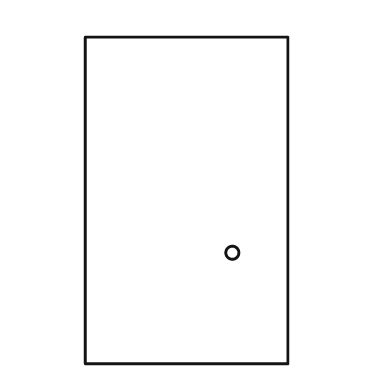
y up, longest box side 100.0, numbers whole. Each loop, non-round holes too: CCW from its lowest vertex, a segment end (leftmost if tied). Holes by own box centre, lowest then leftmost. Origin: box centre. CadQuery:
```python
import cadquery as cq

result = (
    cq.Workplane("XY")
    .moveTo(-31.0, -50.0)
    .lineTo(31.0, -50.0)
    .lineTo(31.0, 50.0)
    .lineTo(-31.0, 50.0)
    .close()
    .moveTo(14.0, -16.0)
    .circle(2.0)
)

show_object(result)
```